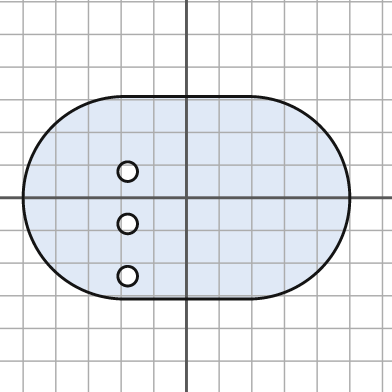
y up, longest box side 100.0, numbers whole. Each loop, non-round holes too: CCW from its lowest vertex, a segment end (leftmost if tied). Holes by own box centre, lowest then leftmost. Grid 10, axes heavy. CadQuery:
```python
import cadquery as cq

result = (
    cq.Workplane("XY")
    .moveTo(-19.0, -31.0)
    .lineTo(19.0, -31.0)
    .threePointArc((50.0, 0.0), (19.0, 31.0))
    .lineTo(-19.0, 31.0)
    .threePointArc((-50.0, 0.0), (-19.0, -31.0))
    .close()
    .moveTo(-18.0, -24.0)
    .circle(3.0)
    .moveTo(-18.0, -8.0)
    .circle(3.0)
    .moveTo(-18.0, 8.0)
    .circle(3.0)
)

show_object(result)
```